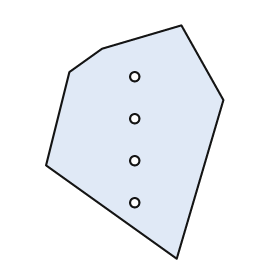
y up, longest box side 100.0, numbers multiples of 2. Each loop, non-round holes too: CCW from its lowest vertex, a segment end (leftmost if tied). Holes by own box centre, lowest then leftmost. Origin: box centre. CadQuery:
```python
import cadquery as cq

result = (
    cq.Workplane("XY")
    .moveTo(18.0, -50.0)
    .lineTo(38.0, 18.0)
    .lineTo(20.0, 50.0)
    .lineTo(-14.0, 40.0)
    .lineTo(-28.0, 30.0)
    .lineTo(-38.0, -10.0)
    .close()
    .moveTo(0.0, -26.0)
    .circle(2.0)
    .moveTo(0.0, -8.0)
    .circle(2.0)
    .moveTo(0.0, 10.0)
    .circle(2.0)
    .moveTo(0.0, 28.0)
    .circle(2.0)
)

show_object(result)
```